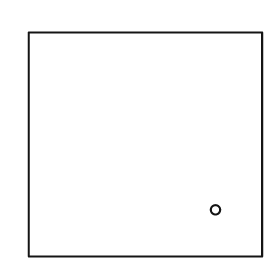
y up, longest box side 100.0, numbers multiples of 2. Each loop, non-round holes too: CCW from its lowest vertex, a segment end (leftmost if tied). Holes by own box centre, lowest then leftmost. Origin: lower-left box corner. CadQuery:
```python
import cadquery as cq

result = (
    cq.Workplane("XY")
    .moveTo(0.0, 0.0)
    .lineTo(100.0, 0.0)
    .lineTo(100.0, 96.0)
    .lineTo(0.0, 96.0)
    .close()
    .moveTo(80.0, 20.0)
    .circle(2.0)
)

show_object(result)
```